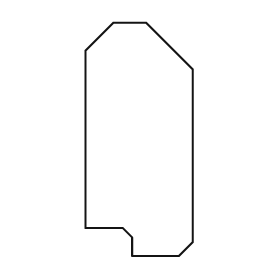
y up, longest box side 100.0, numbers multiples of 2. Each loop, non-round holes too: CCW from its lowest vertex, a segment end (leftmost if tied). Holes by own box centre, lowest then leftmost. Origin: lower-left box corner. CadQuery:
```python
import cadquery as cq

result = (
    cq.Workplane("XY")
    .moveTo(20.0, 0.0)
    .lineTo(40.0, 0.0)
    .lineTo(46.0, 6.0)
    .lineTo(46.0, 80.0)
    .lineTo(26.0, 100.0)
    .lineTo(12.0, 100.0)
    .lineTo(0.0, 88.0)
    .lineTo(0.0, 12.0)
    .lineTo(16.0, 12.0)
    .lineTo(20.0, 8.0)
    .close()
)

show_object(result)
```